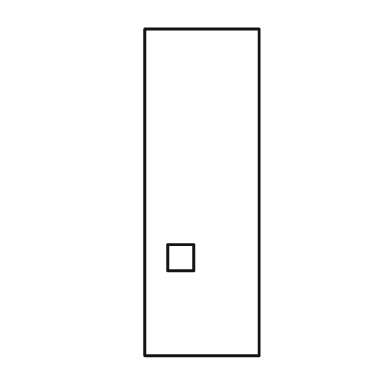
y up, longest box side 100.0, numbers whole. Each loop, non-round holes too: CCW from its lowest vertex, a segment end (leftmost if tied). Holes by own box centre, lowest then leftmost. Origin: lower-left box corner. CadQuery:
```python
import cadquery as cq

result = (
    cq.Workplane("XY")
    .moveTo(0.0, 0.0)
    .lineTo(35.0, 0.0)
    .lineTo(35.0, 100.0)
    .lineTo(0.0, 100.0)
    .close()
    .moveTo(7.0, 26.0)
    .lineTo(15.0, 26.0)
    .lineTo(15.0, 34.0)
    .lineTo(7.0, 34.0)
    .close()
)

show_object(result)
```